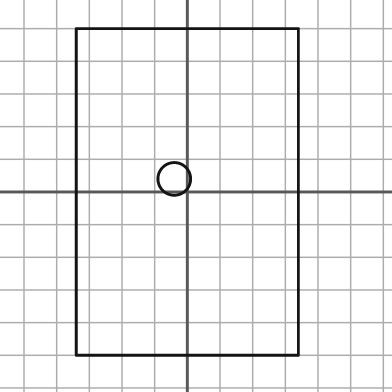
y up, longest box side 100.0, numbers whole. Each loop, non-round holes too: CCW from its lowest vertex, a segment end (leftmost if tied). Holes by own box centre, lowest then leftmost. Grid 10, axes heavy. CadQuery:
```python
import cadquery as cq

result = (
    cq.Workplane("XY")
    .moveTo(-34.0, -50.0)
    .lineTo(34.0, -50.0)
    .lineTo(34.0, 50.0)
    .lineTo(-34.0, 50.0)
    .close()
    .moveTo(-4.0, 4.0)
    .circle(5.0)
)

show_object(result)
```